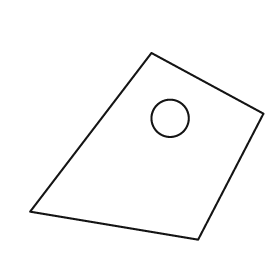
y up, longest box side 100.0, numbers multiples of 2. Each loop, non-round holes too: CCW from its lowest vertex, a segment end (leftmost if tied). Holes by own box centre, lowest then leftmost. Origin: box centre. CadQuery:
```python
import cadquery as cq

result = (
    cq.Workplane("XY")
    .moveTo(22.0, -40.0)
    .lineTo(50.0, 14.0)
    .lineTo(2.0, 40.0)
    .lineTo(-50.0, -28.0)
    .close()
    .moveTo(10.0, 12.0)
    .circle(8.0)
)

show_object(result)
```